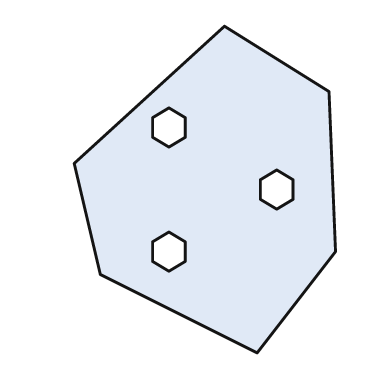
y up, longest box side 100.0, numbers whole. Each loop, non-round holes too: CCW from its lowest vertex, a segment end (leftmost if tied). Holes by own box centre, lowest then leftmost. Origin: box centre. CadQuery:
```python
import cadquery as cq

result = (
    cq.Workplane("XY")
    .moveTo(16.0, -50.0)
    .lineTo(40.0, -19.0)
    .lineTo(38.0, 30.0)
    .lineTo(6.0, 50.0)
    .lineTo(-40.0, 8.0)
    .lineTo(-32.0, -26.0)
    .close()
    .moveTo(-11.0, -25.0)
    .lineTo(-6.0, -22.0)
    .lineTo(-6.0, -16.0)
    .lineTo(-11.0, -13.0)
    .lineTo(-16.0, -16.0)
    .lineTo(-16.0, -22.0)
    .close()
    .moveTo(22.0, -6.0)
    .lineTo(27.0, -3.0)
    .lineTo(27.0, 3.0)
    .lineTo(22.0, 6.0)
    .lineTo(17.0, 3.0)
    .lineTo(17.0, -3.0)
    .close()
    .moveTo(-11.0, 13.0)
    .lineTo(-6.0, 16.0)
    .lineTo(-6.0, 22.0)
    .lineTo(-11.0, 25.0)
    .lineTo(-16.0, 22.0)
    .lineTo(-16.0, 16.0)
    .close()
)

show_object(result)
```